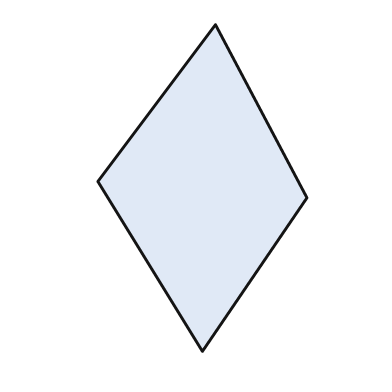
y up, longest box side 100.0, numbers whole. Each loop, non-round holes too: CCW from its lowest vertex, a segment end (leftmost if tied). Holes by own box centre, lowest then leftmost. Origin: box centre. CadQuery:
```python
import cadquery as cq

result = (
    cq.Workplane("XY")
    .moveTo(0.0, -50.0)
    .lineTo(32.0, -3.0)
    .lineTo(4.0, 50.0)
    .lineTo(-32.0, 2.0)
    .close()
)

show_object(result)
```